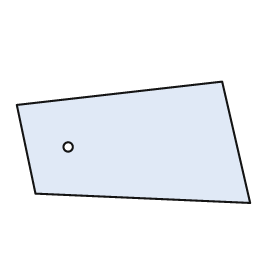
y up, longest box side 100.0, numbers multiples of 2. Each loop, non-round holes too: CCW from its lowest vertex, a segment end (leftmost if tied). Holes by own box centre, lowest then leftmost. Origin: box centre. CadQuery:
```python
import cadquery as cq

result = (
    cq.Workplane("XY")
    .moveTo(50.0, -26.0)
    .lineTo(38.0, 26.0)
    .lineTo(-50.0, 16.0)
    .lineTo(-42.0, -22.0)
    .close()
    .moveTo(-28.0, -2.0)
    .circle(2.0)
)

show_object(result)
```